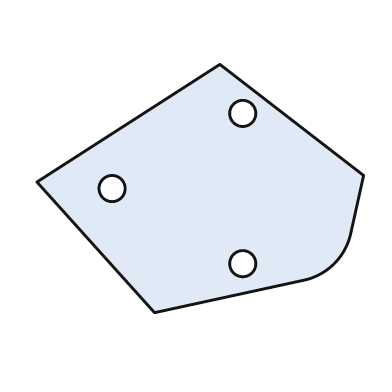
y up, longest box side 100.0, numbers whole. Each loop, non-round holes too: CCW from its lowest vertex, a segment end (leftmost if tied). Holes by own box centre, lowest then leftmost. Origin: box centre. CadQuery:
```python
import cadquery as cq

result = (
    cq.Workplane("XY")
    .moveTo(-14.0, -38.0)
    .lineTo(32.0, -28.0)
    .threePointArc((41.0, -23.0), (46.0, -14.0))
    .lineTo(50.0, 4.0)
    .lineTo(6.0, 38.0)
    .lineTo(-50.0, 2.0)
    .close()
    .moveTo(13.0, -23.0)
    .circle(4.0)
    .moveTo(-27.0, 0.0)
    .circle(4.0)
    .moveTo(13.0, 23.0)
    .circle(4.0)
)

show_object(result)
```